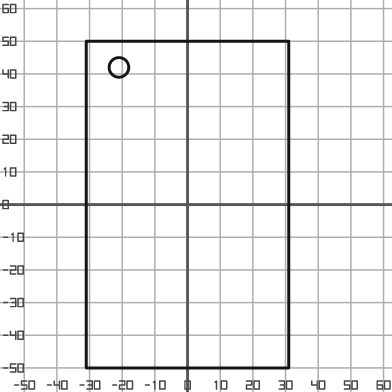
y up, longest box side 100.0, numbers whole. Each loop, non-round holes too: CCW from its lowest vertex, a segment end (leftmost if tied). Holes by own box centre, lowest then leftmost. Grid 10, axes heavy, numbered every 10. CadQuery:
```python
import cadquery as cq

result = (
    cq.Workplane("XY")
    .moveTo(-31.0, -50.0)
    .lineTo(31.0, -50.0)
    .lineTo(31.0, 50.0)
    .lineTo(-31.0, 50.0)
    .close()
    .moveTo(-21.0, 42.0)
    .circle(3.0)
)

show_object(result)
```